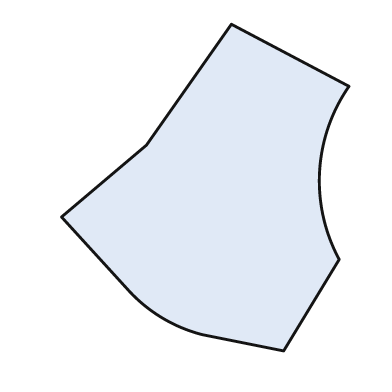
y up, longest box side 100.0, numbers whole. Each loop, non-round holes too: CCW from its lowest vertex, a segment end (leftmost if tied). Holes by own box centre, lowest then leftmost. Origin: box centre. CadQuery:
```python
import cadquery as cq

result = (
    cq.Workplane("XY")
    .moveTo(24.0, -50.0)
    .lineTo(41.0, -22.0)
    .threePointArc((35.0, 5.0), (44.0, 31.0))
    .lineTo(8.0, 50.0)
    .lineTo(-18.0, 13.0)
    .lineTo(-44.0, -9.0)
    .lineTo(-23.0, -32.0)
    .threePointArc((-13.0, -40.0), (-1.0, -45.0))
    .close()
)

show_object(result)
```